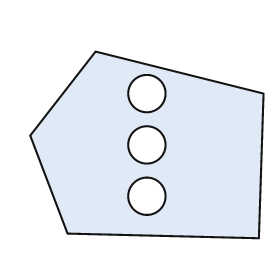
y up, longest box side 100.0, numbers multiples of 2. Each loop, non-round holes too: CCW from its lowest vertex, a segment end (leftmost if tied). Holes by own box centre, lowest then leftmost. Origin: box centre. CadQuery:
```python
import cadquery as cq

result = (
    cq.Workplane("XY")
    .moveTo(48.0, -40.0)
    .lineTo(50.0, 22.0)
    .lineTo(-22.0, 40.0)
    .lineTo(-50.0, 4.0)
    .lineTo(-34.0, -38.0)
    .close()
    .moveTo(0.0, -22.0)
    .circle(8.0)
    .moveTo(0.0, 0.0)
    .circle(8.0)
    .moveTo(0.0, 22.0)
    .circle(8.0)
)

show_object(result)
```